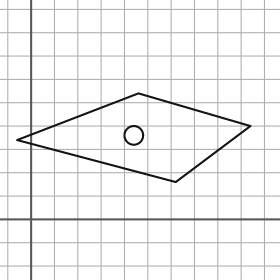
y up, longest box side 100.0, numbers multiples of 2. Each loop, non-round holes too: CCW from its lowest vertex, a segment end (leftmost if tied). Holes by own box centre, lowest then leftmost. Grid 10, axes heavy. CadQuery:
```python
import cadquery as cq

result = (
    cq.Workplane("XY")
    .moveTo(62.0, 16.0)
    .lineTo(94.0, 40.0)
    .lineTo(46.0, 54.0)
    .lineTo(-6.0, 34.0)
    .close()
    .moveTo(44.0, 36.0)
    .circle(4.0)
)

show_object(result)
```